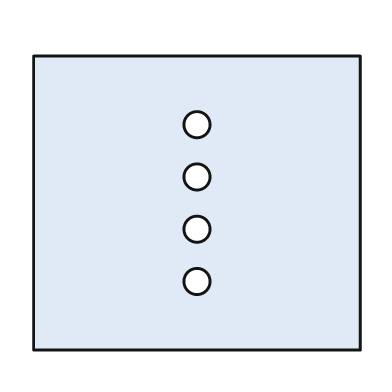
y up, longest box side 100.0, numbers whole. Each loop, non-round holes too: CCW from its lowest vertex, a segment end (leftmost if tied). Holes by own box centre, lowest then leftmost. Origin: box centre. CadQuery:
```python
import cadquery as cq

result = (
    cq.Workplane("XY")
    .moveTo(-50.0, -45.0)
    .lineTo(50.0, -45.0)
    .lineTo(50.0, 45.0)
    .lineTo(-50.0, 45.0)
    .close()
    .moveTo(0.0, -24.0)
    .circle(4.0)
    .moveTo(0.0, -8.0)
    .circle(4.0)
    .moveTo(0.0, 8.0)
    .circle(4.0)
    .moveTo(0.0, 24.0)
    .circle(4.0)
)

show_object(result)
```